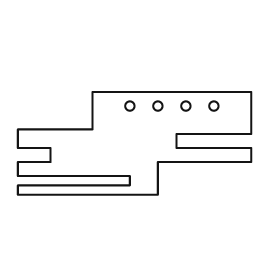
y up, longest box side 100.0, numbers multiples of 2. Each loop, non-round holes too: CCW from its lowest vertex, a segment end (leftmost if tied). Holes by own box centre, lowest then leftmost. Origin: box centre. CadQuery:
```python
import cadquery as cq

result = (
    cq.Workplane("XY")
    .moveTo(-50.0, -22.0)
    .lineTo(10.0, -22.0)
    .lineTo(10.0, -8.0)
    .lineTo(50.0, -8.0)
    .lineTo(50.0, -2.0)
    .lineTo(18.0, -2.0)
    .lineTo(18.0, 4.0)
    .lineTo(50.0, 4.0)
    .lineTo(50.0, 22.0)
    .lineTo(-18.0, 22.0)
    .lineTo(-18.0, 6.0)
    .lineTo(-50.0, 6.0)
    .lineTo(-50.0, -2.0)
    .lineTo(-36.0, -2.0)
    .lineTo(-36.0, -8.0)
    .lineTo(-50.0, -8.0)
    .lineTo(-50.0, -14.0)
    .lineTo(-2.0, -14.0)
    .lineTo(-2.0, -18.0)
    .lineTo(-50.0, -18.0)
    .close()
    .moveTo(-2.0, 16.0)
    .circle(2.0)
    .moveTo(10.0, 16.0)
    .circle(2.0)
    .moveTo(22.0, 16.0)
    .circle(2.0)
    .moveTo(34.0, 16.0)
    .circle(2.0)
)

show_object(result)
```